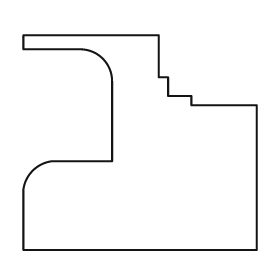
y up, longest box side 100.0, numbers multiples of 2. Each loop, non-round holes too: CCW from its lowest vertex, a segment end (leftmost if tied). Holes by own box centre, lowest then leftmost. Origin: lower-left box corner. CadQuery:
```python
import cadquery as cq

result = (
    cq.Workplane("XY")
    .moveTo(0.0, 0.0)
    .lineTo(100.0, 0.0)
    .lineTo(100.0, 62.0)
    .lineTo(72.0, 62.0)
    .lineTo(72.0, 66.0)
    .lineTo(62.0, 66.0)
    .lineTo(62.0, 74.0)
    .lineTo(58.0, 74.0)
    .lineTo(58.0, 92.0)
    .lineTo(0.0, 92.0)
    .lineTo(0.0, 86.0)
    .lineTo(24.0, 86.0)
    .threePointArc((34.0, 82.0), (38.0, 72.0))
    .lineTo(38.0, 38.0)
    .lineTo(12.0, 38.0)
    .threePointArc((4.0, 34.0), (0.0, 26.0))
    .close()
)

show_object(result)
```